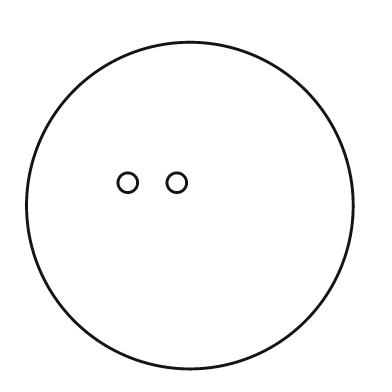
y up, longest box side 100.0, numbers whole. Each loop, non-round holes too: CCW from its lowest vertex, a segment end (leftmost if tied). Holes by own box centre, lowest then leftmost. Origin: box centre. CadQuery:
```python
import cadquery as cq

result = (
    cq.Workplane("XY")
    .moveTo(0.0, 0.0)
    .circle(50.0)
    .moveTo(-19.0, 7.0)
    .circle(3.0)
    .moveTo(-4.0, 7.0)
    .circle(3.0)
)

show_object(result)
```